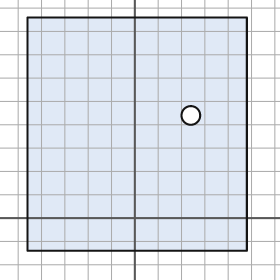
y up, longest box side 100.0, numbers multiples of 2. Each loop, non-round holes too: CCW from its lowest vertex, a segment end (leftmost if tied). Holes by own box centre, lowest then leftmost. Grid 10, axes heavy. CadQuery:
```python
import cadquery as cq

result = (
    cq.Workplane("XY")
    .moveTo(-46.0, -14.0)
    .lineTo(48.0, -14.0)
    .lineTo(48.0, 86.0)
    .lineTo(-46.0, 86.0)
    .close()
    .moveTo(24.0, 44.0)
    .circle(4.0)
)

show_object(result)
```